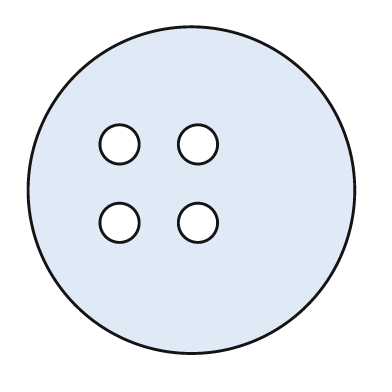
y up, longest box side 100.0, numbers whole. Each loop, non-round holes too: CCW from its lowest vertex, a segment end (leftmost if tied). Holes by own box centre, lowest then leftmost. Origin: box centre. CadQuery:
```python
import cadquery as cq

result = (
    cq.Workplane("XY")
    .moveTo(0.0, 0.0)
    .circle(50.0)
    .moveTo(-22.0, -10.0)
    .circle(6.0)
    .moveTo(2.0, -10.0)
    .circle(6.0)
    .moveTo(-22.0, 14.0)
    .circle(6.0)
    .moveTo(2.0, 14.0)
    .circle(6.0)
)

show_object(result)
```